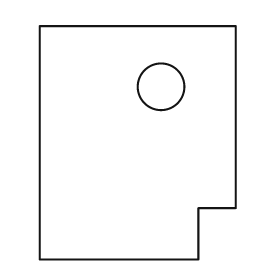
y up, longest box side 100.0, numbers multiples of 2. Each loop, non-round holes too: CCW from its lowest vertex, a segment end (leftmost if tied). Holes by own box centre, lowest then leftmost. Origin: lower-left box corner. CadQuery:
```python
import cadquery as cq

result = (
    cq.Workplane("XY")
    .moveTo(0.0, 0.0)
    .lineTo(68.0, 0.0)
    .lineTo(68.0, 22.0)
    .lineTo(84.0, 22.0)
    .lineTo(84.0, 100.0)
    .lineTo(0.0, 100.0)
    .close()
    .moveTo(52.0, 74.0)
    .circle(10.0)
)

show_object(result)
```